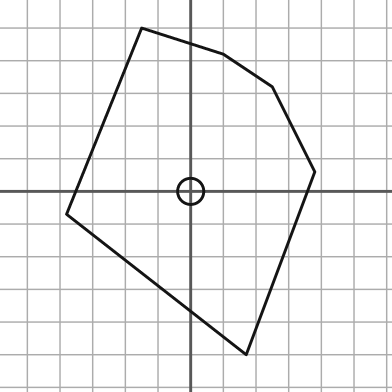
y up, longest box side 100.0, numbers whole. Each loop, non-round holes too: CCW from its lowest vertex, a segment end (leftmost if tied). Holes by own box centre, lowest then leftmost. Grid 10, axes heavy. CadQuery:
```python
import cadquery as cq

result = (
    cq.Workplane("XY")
    .moveTo(17.0, -50.0)
    .lineTo(38.0, 6.0)
    .lineTo(25.0, 32.0)
    .lineTo(10.0, 42.0)
    .lineTo(-15.0, 50.0)
    .lineTo(-38.0, -7.0)
    .close()
    .moveTo(0.0, 0.0)
    .circle(4.0)
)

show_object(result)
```